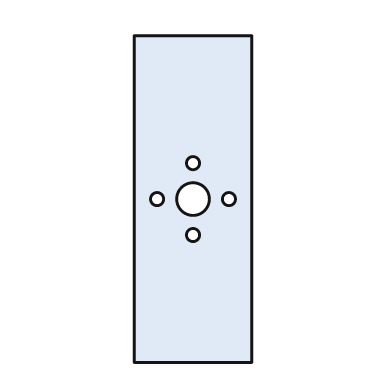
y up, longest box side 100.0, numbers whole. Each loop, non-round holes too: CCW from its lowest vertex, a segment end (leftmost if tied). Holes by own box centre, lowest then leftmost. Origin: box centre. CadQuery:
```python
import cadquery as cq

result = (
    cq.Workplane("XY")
    .moveTo(-18.0, -50.0)
    .lineTo(18.0, -50.0)
    .lineTo(18.0, 50.0)
    .lineTo(-18.0, 50.0)
    .close()
    .moveTo(0.0, -11.0)
    .circle(2.0)
    .moveTo(-11.0, 0.0)
    .circle(2.0)
    .moveTo(0.0, 0.0)
    .circle(5.0)
    .moveTo(11.0, 0.0)
    .circle(2.0)
    .moveTo(0.0, 11.0)
    .circle(2.0)
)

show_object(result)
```